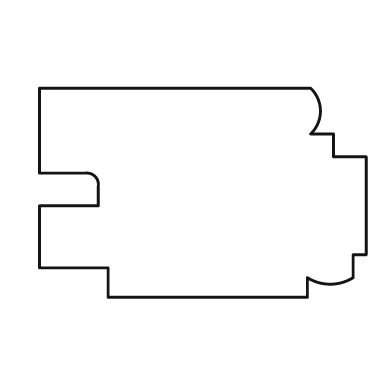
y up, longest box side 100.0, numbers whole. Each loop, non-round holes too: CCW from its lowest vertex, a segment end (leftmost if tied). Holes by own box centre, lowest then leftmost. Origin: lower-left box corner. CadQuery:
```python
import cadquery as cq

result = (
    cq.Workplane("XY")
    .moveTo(21.0, 0.0)
    .lineTo(82.0, 0.0)
    .lineTo(82.0, 6.0)
    .threePointArc((89.0, 4.0), (96.0, 6.0))
    .lineTo(96.0, 13.0)
    .lineTo(100.0, 13.0)
    .lineTo(100.0, 43.0)
    .lineTo(90.0, 43.0)
    .lineTo(90.0, 50.0)
    .lineTo(83.0, 50.0)
    .threePointArc((86.0, 57.0), (83.0, 64.0))
    .lineTo(0.0, 64.0)
    .lineTo(0.0, 38.0)
    .lineTo(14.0, 38.0)
    .threePointArc((17.0, 37.0), (18.0, 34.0))
    .lineTo(18.0, 28.0)
    .lineTo(0.0, 28.0)
    .lineTo(0.0, 9.0)
    .lineTo(21.0, 9.0)
    .close()
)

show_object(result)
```